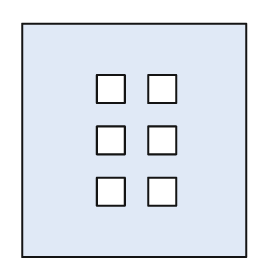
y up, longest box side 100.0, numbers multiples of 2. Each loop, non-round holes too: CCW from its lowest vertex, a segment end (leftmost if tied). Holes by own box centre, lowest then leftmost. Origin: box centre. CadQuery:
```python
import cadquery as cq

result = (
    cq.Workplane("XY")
    .moveTo(-48.0, -50.0)
    .lineTo(48.0, -50.0)
    .lineTo(48.0, 50.0)
    .lineTo(-48.0, 50.0)
    .close()
    .moveTo(-16.0, -28.0)
    .lineTo(-4.0, -28.0)
    .lineTo(-4.0, -16.0)
    .lineTo(-16.0, -16.0)
    .close()
    .moveTo(6.0, -28.0)
    .lineTo(18.0, -28.0)
    .lineTo(18.0, -16.0)
    .lineTo(6.0, -16.0)
    .close()
    .moveTo(-16.0, -6.0)
    .lineTo(-4.0, -6.0)
    .lineTo(-4.0, 6.0)
    .lineTo(-16.0, 6.0)
    .close()
    .moveTo(6.0, -6.0)
    .lineTo(18.0, -6.0)
    .lineTo(18.0, 6.0)
    .lineTo(6.0, 6.0)
    .close()
    .moveTo(-16.0, 16.0)
    .lineTo(-4.0, 16.0)
    .lineTo(-4.0, 28.0)
    .lineTo(-16.0, 28.0)
    .close()
    .moveTo(6.0, 16.0)
    .lineTo(18.0, 16.0)
    .lineTo(18.0, 28.0)
    .lineTo(6.0, 28.0)
    .close()
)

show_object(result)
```